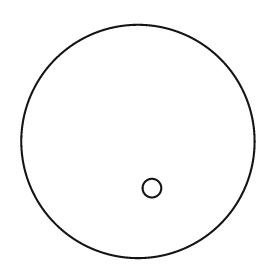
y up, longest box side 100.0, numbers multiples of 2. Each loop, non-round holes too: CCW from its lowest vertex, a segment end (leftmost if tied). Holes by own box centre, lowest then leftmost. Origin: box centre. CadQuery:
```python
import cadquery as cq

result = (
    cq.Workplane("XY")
    .moveTo(0.0, 0.0)
    .circle(50.0)
    .moveTo(6.0, -20.0)
    .circle(4.0)
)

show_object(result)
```